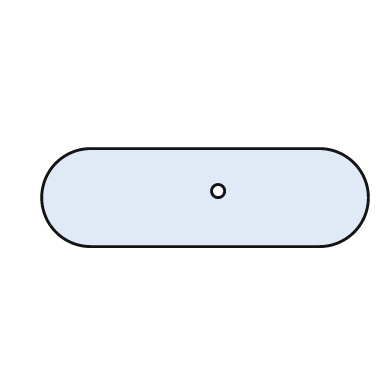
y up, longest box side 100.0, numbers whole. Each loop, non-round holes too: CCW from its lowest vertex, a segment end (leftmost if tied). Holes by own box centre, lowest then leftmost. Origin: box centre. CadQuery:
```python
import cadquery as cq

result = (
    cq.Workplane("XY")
    .moveTo(-35.0, -15.0)
    .lineTo(35.0, -15.0)
    .threePointArc((50.0, 0.0), (35.0, 15.0))
    .lineTo(-35.0, 15.0)
    .threePointArc((-50.0, 0.0), (-35.0, -15.0))
    .close()
    .moveTo(4.0, 2.0)
    .circle(2.0)
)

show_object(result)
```